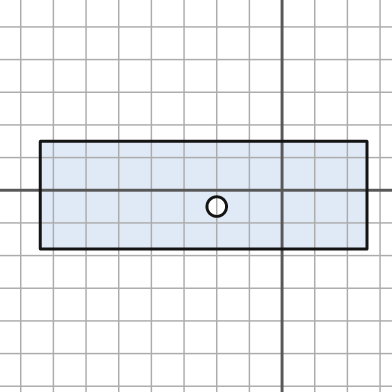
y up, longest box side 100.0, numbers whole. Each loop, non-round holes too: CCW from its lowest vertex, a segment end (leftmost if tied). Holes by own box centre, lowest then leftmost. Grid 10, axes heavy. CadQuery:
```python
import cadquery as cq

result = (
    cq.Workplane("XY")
    .moveTo(-74.0, -18.0)
    .lineTo(26.0, -18.0)
    .lineTo(26.0, 15.0)
    .lineTo(-74.0, 15.0)
    .close()
    .moveTo(-20.0, -5.0)
    .circle(3.0)
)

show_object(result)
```